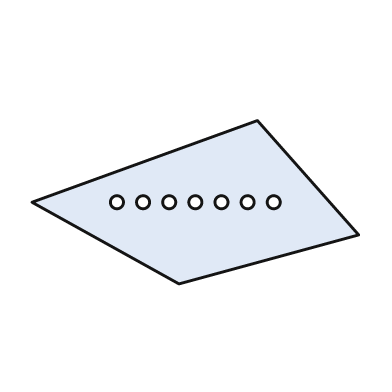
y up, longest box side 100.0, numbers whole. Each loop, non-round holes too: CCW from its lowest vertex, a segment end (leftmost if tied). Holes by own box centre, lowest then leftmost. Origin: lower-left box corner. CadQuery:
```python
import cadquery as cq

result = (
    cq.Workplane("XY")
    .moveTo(45.0, 0.0)
    .lineTo(100.0, 15.0)
    .lineTo(69.0, 50.0)
    .lineTo(0.0, 25.0)
    .close()
    .moveTo(26.0, 25.0)
    .circle(2.0)
    .moveTo(34.0, 25.0)
    .circle(2.0)
    .moveTo(42.0, 25.0)
    .circle(2.0)
    .moveTo(50.0, 25.0)
    .circle(2.0)
    .moveTo(58.0, 25.0)
    .circle(2.0)
    .moveTo(66.0, 25.0)
    .circle(2.0)
    .moveTo(74.0, 25.0)
    .circle(2.0)
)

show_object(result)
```